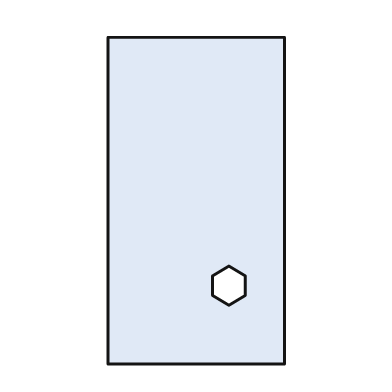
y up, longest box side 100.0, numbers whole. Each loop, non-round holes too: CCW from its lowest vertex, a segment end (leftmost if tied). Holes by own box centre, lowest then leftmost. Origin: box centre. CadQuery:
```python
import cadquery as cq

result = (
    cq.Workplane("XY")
    .moveTo(-27.0, -50.0)
    .lineTo(27.0, -50.0)
    .lineTo(27.0, 50.0)
    .lineTo(-27.0, 50.0)
    .close()
    .moveTo(10.0, -32.0)
    .lineTo(15.0, -29.0)
    .lineTo(15.0, -23.0)
    .lineTo(10.0, -20.0)
    .lineTo(5.0, -23.0)
    .lineTo(5.0, -29.0)
    .close()
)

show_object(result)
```